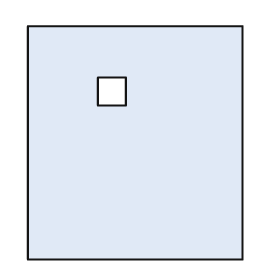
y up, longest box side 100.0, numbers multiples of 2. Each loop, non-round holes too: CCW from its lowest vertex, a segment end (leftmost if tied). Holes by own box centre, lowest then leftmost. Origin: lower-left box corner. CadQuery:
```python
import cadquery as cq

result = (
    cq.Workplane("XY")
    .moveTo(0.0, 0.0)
    .lineTo(92.0, 0.0)
    .lineTo(92.0, 100.0)
    .lineTo(0.0, 100.0)
    .close()
    .moveTo(30.0, 66.0)
    .lineTo(42.0, 66.0)
    .lineTo(42.0, 78.0)
    .lineTo(30.0, 78.0)
    .close()
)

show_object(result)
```